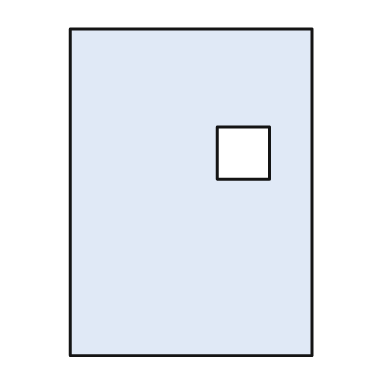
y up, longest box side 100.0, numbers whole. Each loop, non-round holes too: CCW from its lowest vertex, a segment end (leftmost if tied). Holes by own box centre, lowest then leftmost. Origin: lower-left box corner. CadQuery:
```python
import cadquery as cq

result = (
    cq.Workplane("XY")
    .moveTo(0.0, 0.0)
    .lineTo(74.0, 0.0)
    .lineTo(74.0, 100.0)
    .lineTo(0.0, 100.0)
    .close()
    .moveTo(45.0, 54.0)
    .lineTo(61.0, 54.0)
    .lineTo(61.0, 70.0)
    .lineTo(45.0, 70.0)
    .close()
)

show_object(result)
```